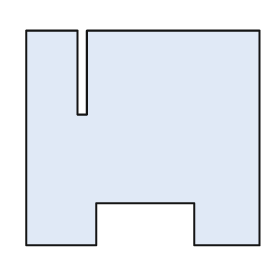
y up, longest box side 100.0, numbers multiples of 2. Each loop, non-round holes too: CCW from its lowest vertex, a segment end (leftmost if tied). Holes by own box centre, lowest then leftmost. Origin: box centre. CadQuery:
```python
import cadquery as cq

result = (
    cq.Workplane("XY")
    .moveTo(-50.0, -46.0)
    .lineTo(-20.0, -46.0)
    .lineTo(-20.0, -28.0)
    .lineTo(22.0, -28.0)
    .lineTo(22.0, -46.0)
    .lineTo(50.0, -46.0)
    .lineTo(50.0, 46.0)
    .lineTo(-24.0, 46.0)
    .lineTo(-24.0, 10.0)
    .lineTo(-28.0, 10.0)
    .lineTo(-28.0, 46.0)
    .lineTo(-50.0, 46.0)
    .close()
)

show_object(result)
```